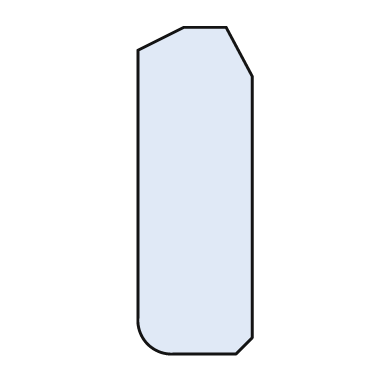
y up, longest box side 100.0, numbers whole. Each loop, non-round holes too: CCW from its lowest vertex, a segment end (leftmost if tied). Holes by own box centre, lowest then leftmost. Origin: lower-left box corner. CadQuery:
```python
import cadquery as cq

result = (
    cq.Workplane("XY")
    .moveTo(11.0, 0.0)
    .lineTo(30.0, 0.0)
    .lineTo(35.0, 5.0)
    .lineTo(35.0, 85.0)
    .lineTo(27.0, 100.0)
    .lineTo(14.0, 100.0)
    .lineTo(0.0, 93.0)
    .lineTo(0.0, 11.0)
    .threePointArc((3.0, 3.0), (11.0, 0.0))
    .close()
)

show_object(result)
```